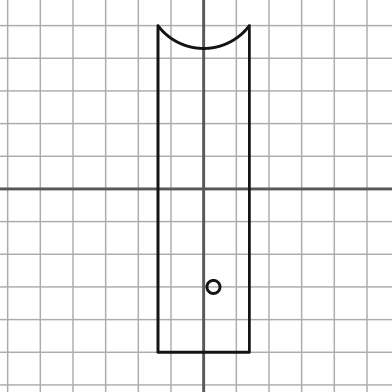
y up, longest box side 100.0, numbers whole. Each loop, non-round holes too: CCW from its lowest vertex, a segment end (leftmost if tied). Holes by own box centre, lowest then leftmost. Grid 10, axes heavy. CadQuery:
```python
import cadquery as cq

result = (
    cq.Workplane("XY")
    .moveTo(-14.0, -50.0)
    .lineTo(14.0, -50.0)
    .lineTo(14.0, 50.0)
    .threePointArc((0.0, 43.0), (-14.0, 50.0))
    .close()
    .moveTo(3.0, -30.0)
    .circle(2.0)
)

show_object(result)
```